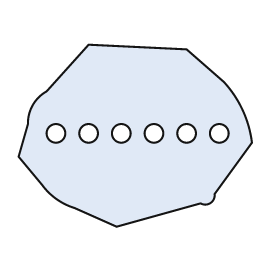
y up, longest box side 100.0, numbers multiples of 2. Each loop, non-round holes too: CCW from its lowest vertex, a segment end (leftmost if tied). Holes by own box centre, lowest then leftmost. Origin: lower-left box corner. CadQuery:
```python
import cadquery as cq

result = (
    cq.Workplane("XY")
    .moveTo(42.0, 0.0)
    .lineTo(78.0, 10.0)
    .threePointArc((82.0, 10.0), (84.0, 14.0))
    .lineTo(100.0, 36.0)
    .threePointArc((96.0, 50.0), (88.0, 62.0))
    .lineTo(72.0, 76.0)
    .lineTo(30.0, 78.0)
    .lineTo(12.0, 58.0)
    .threePointArc((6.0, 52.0), (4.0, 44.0))
    .lineTo(0.0, 30.0)
    .lineTo(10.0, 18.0)
    .threePointArc((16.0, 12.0), (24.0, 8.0))
    .close()
    .moveTo(16.0, 40.0)
    .circle(4.0)
    .moveTo(30.0, 40.0)
    .circle(4.0)
    .moveTo(44.0, 40.0)
    .circle(4.0)
    .moveTo(58.0, 40.0)
    .circle(4.0)
    .moveTo(72.0, 40.0)
    .circle(4.0)
    .moveTo(86.0, 40.0)
    .circle(4.0)
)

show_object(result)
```